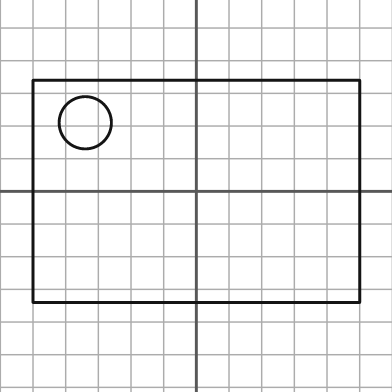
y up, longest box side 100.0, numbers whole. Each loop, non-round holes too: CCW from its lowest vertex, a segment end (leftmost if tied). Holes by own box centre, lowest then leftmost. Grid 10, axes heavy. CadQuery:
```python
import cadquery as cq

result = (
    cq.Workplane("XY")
    .moveTo(-50.0, -34.0)
    .lineTo(50.0, -34.0)
    .lineTo(50.0, 34.0)
    .lineTo(-50.0, 34.0)
    .close()
    .moveTo(-34.0, 21.0)
    .circle(8.0)
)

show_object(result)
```